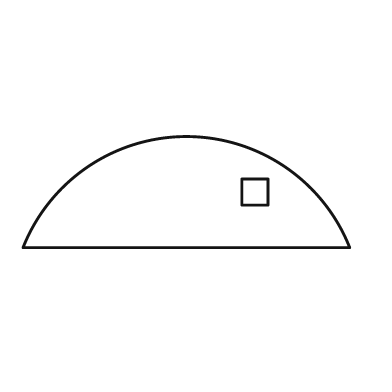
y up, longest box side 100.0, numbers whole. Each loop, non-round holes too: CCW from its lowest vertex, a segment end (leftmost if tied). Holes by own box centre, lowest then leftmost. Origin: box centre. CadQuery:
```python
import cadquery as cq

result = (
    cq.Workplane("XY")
    .moveTo(-50.0, -17.0)
    .lineTo(50.0, -17.0)
    .threePointArc((0.0, 17.0), (-50.0, -17.0))
    .close()
    .moveTo(17.0, -4.0)
    .lineTo(25.0, -4.0)
    .lineTo(25.0, 4.0)
    .lineTo(17.0, 4.0)
    .close()
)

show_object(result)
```